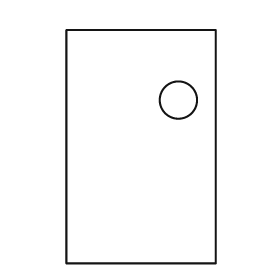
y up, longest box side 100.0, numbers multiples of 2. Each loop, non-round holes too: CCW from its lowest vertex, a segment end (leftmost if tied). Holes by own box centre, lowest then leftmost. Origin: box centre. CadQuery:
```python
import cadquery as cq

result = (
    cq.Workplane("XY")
    .moveTo(-32.0, -50.0)
    .lineTo(32.0, -50.0)
    .lineTo(32.0, 50.0)
    .lineTo(-32.0, 50.0)
    .close()
    .moveTo(16.0, 20.0)
    .circle(8.0)
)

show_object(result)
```